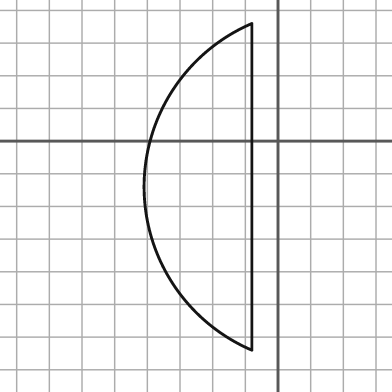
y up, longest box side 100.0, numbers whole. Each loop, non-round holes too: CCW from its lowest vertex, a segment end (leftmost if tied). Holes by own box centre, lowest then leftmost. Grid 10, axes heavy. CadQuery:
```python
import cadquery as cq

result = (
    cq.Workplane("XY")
    .moveTo(-8.0, -64.0)
    .lineTo(-8.0, 36.0)
    .threePointArc((-41.0, -14.0), (-8.0, -64.0))
    .close()
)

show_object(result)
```